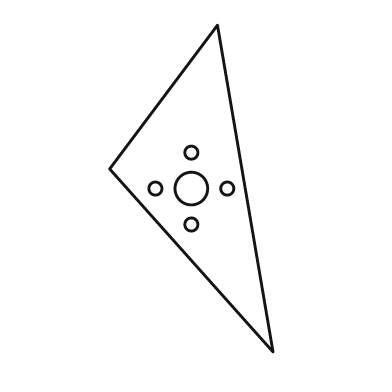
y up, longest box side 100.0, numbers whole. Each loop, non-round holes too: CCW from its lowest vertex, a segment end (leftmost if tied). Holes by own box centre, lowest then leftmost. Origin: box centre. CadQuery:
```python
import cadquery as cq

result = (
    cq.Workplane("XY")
    .moveTo(25.0, -50.0)
    .lineTo(8.0, 50.0)
    .lineTo(-25.0, 6.0)
    .close()
    .moveTo(0.0, -11.0)
    .circle(2.0)
    .moveTo(-11.0, 0.0)
    .circle(2.0)
    .moveTo(0.0, 0.0)
    .circle(5.0)
    .moveTo(11.0, 0.0)
    .circle(2.0)
    .moveTo(0.0, 11.0)
    .circle(2.0)
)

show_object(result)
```